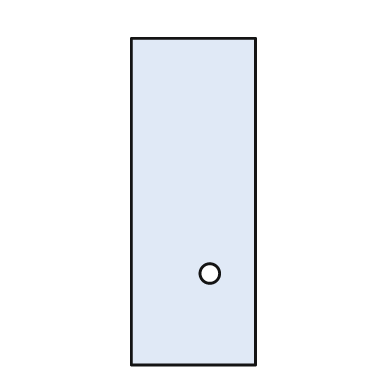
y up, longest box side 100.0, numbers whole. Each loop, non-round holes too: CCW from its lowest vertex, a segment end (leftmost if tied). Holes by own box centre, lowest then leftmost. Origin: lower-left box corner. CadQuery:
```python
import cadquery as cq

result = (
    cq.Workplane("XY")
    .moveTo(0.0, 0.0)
    .lineTo(38.0, 0.0)
    .lineTo(38.0, 100.0)
    .lineTo(0.0, 100.0)
    .close()
    .moveTo(24.0, 28.0)
    .circle(3.0)
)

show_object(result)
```